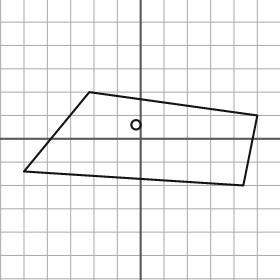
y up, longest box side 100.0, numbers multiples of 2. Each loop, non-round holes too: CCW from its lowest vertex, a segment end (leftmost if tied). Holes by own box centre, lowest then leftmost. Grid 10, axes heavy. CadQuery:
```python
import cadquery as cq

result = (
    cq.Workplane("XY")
    .moveTo(44.0, -20.0)
    .lineTo(50.0, 10.0)
    .lineTo(-22.0, 20.0)
    .lineTo(-50.0, -14.0)
    .close()
    .moveTo(-2.0, 6.0)
    .circle(2.0)
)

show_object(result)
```